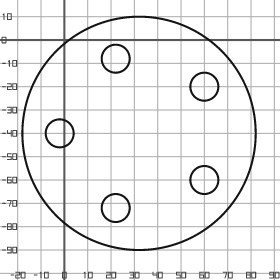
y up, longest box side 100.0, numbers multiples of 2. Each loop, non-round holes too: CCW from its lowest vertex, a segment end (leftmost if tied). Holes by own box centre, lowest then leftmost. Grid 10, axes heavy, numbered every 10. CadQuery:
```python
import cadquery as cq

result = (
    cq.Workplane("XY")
    .moveTo(32.0, -40.0)
    .circle(50.0)
    .moveTo(22.0, -72.0)
    .circle(6.0)
    .moveTo(60.0, -60.0)
    .circle(6.0)
    .moveTo(-2.0, -40.0)
    .circle(6.0)
    .moveTo(60.0, -20.0)
    .circle(6.0)
    .moveTo(22.0, -8.0)
    .circle(6.0)
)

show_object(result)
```